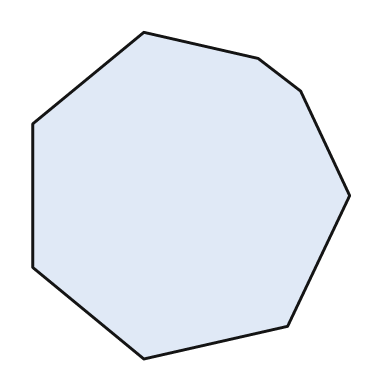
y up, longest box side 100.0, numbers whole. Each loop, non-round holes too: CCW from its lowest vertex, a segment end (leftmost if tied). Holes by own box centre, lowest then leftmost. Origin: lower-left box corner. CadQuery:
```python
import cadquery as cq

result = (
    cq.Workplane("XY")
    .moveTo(34.0, 0.0)
    .lineTo(78.0, 10.0)
    .lineTo(97.0, 50.0)
    .lineTo(82.0, 82.0)
    .lineTo(69.0, 92.0)
    .lineTo(34.0, 100.0)
    .lineTo(0.0, 72.0)
    .lineTo(0.0, 28.0)
    .close()
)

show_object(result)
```